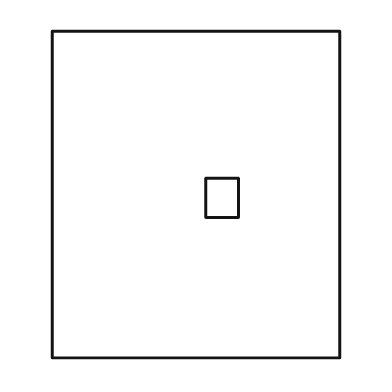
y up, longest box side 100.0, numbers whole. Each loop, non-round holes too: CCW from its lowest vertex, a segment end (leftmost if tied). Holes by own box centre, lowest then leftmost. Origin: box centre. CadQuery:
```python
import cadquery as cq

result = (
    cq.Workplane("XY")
    .moveTo(-44.0, -50.0)
    .lineTo(44.0, -50.0)
    .lineTo(44.0, 50.0)
    .lineTo(-44.0, 50.0)
    .close()
    .moveTo(3.0, -7.0)
    .lineTo(13.0, -7.0)
    .lineTo(13.0, 5.0)
    .lineTo(3.0, 5.0)
    .close()
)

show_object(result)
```